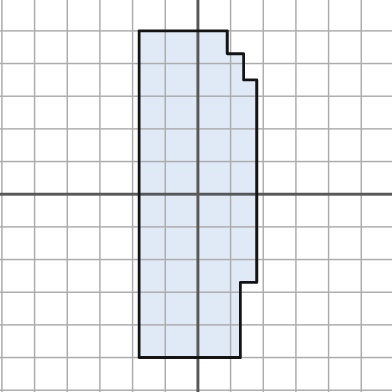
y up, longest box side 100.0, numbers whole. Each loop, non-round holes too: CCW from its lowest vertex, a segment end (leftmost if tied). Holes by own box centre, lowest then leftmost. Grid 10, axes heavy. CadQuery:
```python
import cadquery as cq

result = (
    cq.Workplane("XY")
    .moveTo(-18.0, -50.0)
    .lineTo(13.0, -50.0)
    .lineTo(13.0, -27.0)
    .lineTo(18.0, -27.0)
    .lineTo(18.0, 35.0)
    .lineTo(14.0, 35.0)
    .lineTo(14.0, 43.0)
    .lineTo(9.0, 43.0)
    .lineTo(9.0, 50.0)
    .lineTo(-18.0, 50.0)
    .close()
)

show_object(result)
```